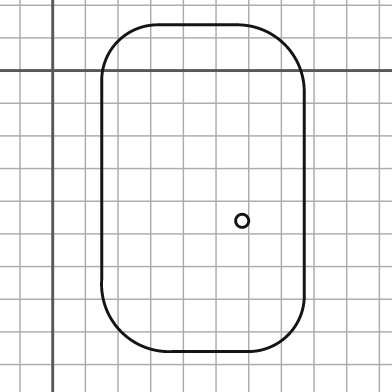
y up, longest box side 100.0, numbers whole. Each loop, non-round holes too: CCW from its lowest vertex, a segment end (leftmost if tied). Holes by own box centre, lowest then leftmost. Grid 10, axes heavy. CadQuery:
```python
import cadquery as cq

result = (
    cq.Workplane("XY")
    .moveTo(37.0, -86.0)
    .lineTo(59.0, -86.0)
    .threePointArc((72.0, -81.0), (77.0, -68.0))
    .lineTo(77.0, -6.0)
    .threePointArc((71.0, 8.0), (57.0, 14.0))
    .lineTo(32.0, 14.0)
    .threePointArc((20.0, 9.0), (15.0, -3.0))
    .lineTo(15.0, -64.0)
    .threePointArc((21.0, -80.0), (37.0, -86.0))
    .close()
    .moveTo(58.0, -46.0)
    .circle(2.0)
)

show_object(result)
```